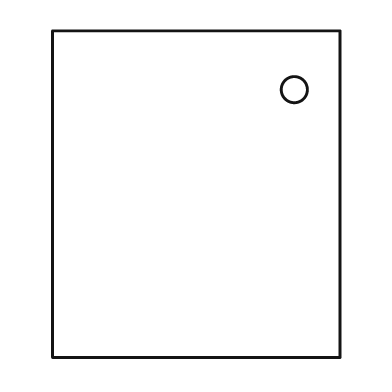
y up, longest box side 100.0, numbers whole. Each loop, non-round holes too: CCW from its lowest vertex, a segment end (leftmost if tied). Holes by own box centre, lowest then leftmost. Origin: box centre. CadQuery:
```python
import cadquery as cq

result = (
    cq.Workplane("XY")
    .moveTo(-44.0, -50.0)
    .lineTo(44.0, -50.0)
    .lineTo(44.0, 50.0)
    .lineTo(-44.0, 50.0)
    .close()
    .moveTo(30.0, 32.0)
    .circle(4.0)
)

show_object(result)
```